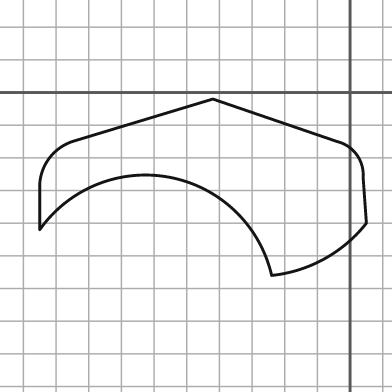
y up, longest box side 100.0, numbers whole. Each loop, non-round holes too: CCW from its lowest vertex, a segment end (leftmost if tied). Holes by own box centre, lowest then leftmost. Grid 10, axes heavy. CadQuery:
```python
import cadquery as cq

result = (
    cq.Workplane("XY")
    .moveTo(-24.0, -56.0)
    .threePointArc((-8.0, -51.0), (5.0, -40.0))
    .lineTo(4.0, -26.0)
    .threePointArc((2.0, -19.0), (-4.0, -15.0))
    .lineTo(-42.0, -2.0)
    .lineTo(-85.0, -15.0)
    .threePointArc((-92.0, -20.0), (-95.0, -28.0))
    .lineTo(-95.0, -42.0)
    .threePointArc((-55.0, -26.0), (-24.0, -56.0))
    .close()
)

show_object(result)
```